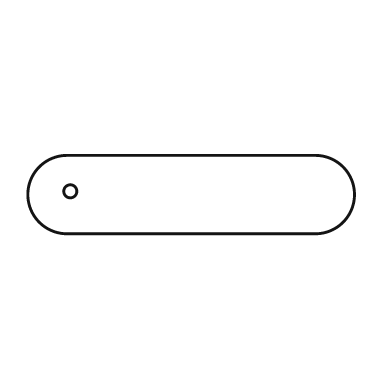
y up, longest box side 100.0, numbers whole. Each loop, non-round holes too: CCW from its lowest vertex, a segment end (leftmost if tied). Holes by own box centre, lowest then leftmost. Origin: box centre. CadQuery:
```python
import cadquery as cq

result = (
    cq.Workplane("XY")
    .moveTo(-38.0, -12.0)
    .lineTo(38.0, -12.0)
    .threePointArc((50.0, 0.0), (38.0, 12.0))
    .lineTo(-38.0, 12.0)
    .threePointArc((-50.0, 0.0), (-38.0, -12.0))
    .close()
    .moveTo(-37.0, 1.0)
    .circle(2.0)
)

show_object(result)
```